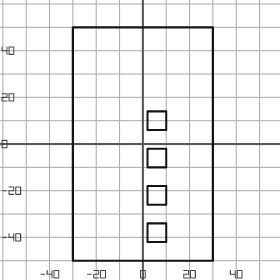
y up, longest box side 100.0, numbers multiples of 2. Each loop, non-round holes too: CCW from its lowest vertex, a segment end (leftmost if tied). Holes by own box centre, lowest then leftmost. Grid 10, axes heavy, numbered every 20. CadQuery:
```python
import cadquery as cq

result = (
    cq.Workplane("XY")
    .moveTo(-30.0, -50.0)
    .lineTo(30.0, -50.0)
    .lineTo(30.0, 50.0)
    .lineTo(-30.0, 50.0)
    .close()
    .moveTo(2.0, -42.0)
    .lineTo(10.0, -42.0)
    .lineTo(10.0, -34.0)
    .lineTo(2.0, -34.0)
    .close()
    .moveTo(2.0, -26.0)
    .lineTo(10.0, -26.0)
    .lineTo(10.0, -18.0)
    .lineTo(2.0, -18.0)
    .close()
    .moveTo(2.0, -10.0)
    .lineTo(10.0, -10.0)
    .lineTo(10.0, -2.0)
    .lineTo(2.0, -2.0)
    .close()
    .moveTo(2.0, 6.0)
    .lineTo(10.0, 6.0)
    .lineTo(10.0, 14.0)
    .lineTo(2.0, 14.0)
    .close()
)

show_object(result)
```